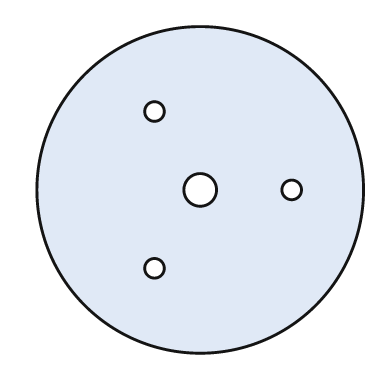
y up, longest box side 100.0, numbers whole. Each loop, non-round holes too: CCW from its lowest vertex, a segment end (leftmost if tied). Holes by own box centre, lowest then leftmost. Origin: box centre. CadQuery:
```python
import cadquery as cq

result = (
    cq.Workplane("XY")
    .moveTo(0.0, 0.0)
    .circle(50.0)
    .moveTo(-14.0, -24.0)
    .circle(3.0)
    .moveTo(0.0, 0.0)
    .circle(5.0)
    .moveTo(28.0, 0.0)
    .circle(3.0)
    .moveTo(-14.0, 24.0)
    .circle(3.0)
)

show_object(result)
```